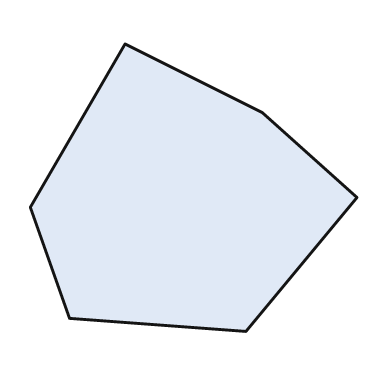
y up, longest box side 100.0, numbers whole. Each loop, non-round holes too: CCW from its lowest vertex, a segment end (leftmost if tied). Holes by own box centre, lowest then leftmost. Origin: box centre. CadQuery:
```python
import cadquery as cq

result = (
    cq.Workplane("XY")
    .moveTo(16.0, -44.0)
    .lineTo(50.0, -3.0)
    .lineTo(21.0, 23.0)
    .lineTo(-21.0, 44.0)
    .lineTo(-50.0, -6.0)
    .lineTo(-38.0, -40.0)
    .close()
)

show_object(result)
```